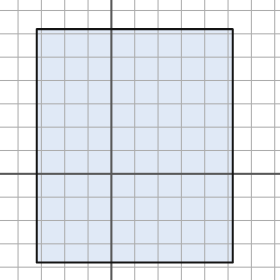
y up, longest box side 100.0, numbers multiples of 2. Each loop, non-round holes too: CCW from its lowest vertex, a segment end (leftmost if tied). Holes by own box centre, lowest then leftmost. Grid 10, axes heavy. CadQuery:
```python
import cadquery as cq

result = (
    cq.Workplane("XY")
    .moveTo(-32.0, -38.0)
    .lineTo(52.0, -38.0)
    .lineTo(52.0, 62.0)
    .lineTo(-32.0, 62.0)
    .close()
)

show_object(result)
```